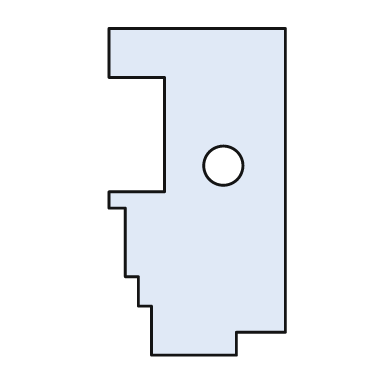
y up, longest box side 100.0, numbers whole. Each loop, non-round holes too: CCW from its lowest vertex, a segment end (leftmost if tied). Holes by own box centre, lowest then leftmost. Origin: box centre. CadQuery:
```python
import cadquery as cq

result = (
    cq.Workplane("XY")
    .moveTo(-14.0, -50.0)
    .lineTo(12.0, -50.0)
    .lineTo(12.0, -43.0)
    .lineTo(27.0, -43.0)
    .lineTo(27.0, 50.0)
    .lineTo(-27.0, 50.0)
    .lineTo(-27.0, 35.0)
    .lineTo(-10.0, 35.0)
    .lineTo(-10.0, 0.0)
    .lineTo(-27.0, 0.0)
    .lineTo(-27.0, -5.0)
    .lineTo(-22.0, -5.0)
    .lineTo(-22.0, -26.0)
    .lineTo(-18.0, -26.0)
    .lineTo(-18.0, -35.0)
    .lineTo(-14.0, -35.0)
    .close()
    .moveTo(8.0, 8.0)
    .circle(6.0)
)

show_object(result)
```